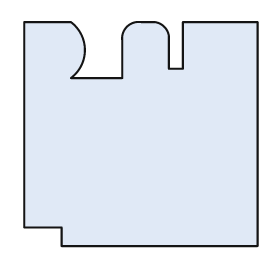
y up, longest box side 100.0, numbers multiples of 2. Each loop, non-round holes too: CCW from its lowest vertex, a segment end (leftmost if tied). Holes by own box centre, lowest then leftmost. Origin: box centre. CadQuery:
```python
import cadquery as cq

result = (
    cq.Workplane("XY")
    .moveTo(-34.0, -48.0)
    .lineTo(50.0, -48.0)
    .lineTo(50.0, 48.0)
    .lineTo(18.0, 48.0)
    .lineTo(18.0, 28.0)
    .lineTo(12.0, 28.0)
    .lineTo(12.0, 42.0)
    .threePointArc((10.0, 46.0), (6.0, 48.0))
    .lineTo(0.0, 48.0)
    .threePointArc((-6.0, 46.0), (-8.0, 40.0))
    .lineTo(-8.0, 24.0)
    .lineTo(-30.0, 24.0)
    .threePointArc((-24.0, 36.0), (-30.0, 48.0))
    .lineTo(-50.0, 48.0)
    .lineTo(-50.0, -40.0)
    .lineTo(-34.0, -40.0)
    .close()
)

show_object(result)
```